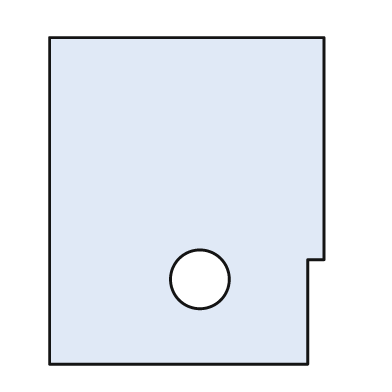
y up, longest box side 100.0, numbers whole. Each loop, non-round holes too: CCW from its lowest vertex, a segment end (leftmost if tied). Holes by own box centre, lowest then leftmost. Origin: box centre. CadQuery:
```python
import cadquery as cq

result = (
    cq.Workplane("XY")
    .moveTo(-42.0, -50.0)
    .lineTo(37.0, -50.0)
    .lineTo(37.0, -18.0)
    .lineTo(42.0, -18.0)
    .lineTo(42.0, 50.0)
    .lineTo(-42.0, 50.0)
    .close()
    .moveTo(4.0, -24.0)
    .circle(9.0)
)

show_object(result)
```